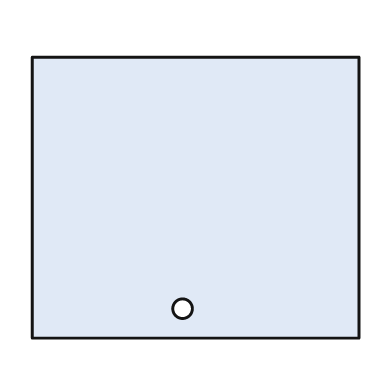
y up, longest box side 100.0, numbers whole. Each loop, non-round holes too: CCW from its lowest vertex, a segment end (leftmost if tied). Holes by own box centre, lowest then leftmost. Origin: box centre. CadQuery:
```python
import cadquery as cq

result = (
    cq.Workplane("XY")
    .moveTo(-50.0, -43.0)
    .lineTo(50.0, -43.0)
    .lineTo(50.0, 43.0)
    .lineTo(-50.0, 43.0)
    .close()
    .moveTo(-4.0, -34.0)
    .circle(3.0)
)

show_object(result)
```